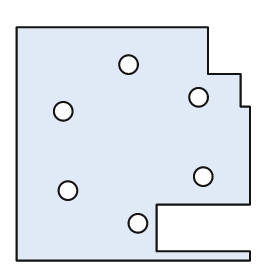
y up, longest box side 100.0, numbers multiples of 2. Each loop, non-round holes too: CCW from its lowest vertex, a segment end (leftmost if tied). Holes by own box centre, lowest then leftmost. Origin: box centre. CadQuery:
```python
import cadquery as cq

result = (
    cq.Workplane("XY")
    .moveTo(-50.0, -50.0)
    .lineTo(50.0, -50.0)
    .lineTo(50.0, -46.0)
    .lineTo(10.0, -46.0)
    .lineTo(10.0, -26.0)
    .lineTo(50.0, -26.0)
    .lineTo(50.0, 16.0)
    .lineTo(46.0, 16.0)
    .lineTo(46.0, 30.0)
    .lineTo(32.0, 30.0)
    .lineTo(32.0, 50.0)
    .lineTo(-50.0, 50.0)
    .close()
    .moveTo(2.0, -34.0)
    .circle(4.0)
    .moveTo(-28.0, -20.0)
    .circle(4.0)
    .moveTo(30.0, -14.0)
    .circle(4.0)
    .moveTo(-30.0, 14.0)
    .circle(4.0)
    .moveTo(28.0, 20.0)
    .circle(4.0)
    .moveTo(-2.0, 34.0)
    .circle(4.0)
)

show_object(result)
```